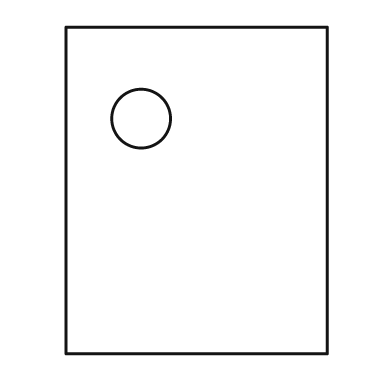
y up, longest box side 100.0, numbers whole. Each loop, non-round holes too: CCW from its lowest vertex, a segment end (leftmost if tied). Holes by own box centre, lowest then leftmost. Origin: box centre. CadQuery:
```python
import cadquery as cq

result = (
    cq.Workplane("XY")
    .moveTo(-40.0, -50.0)
    .lineTo(40.0, -50.0)
    .lineTo(40.0, 50.0)
    .lineTo(-40.0, 50.0)
    .close()
    .moveTo(-17.0, 22.0)
    .circle(9.0)
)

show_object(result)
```